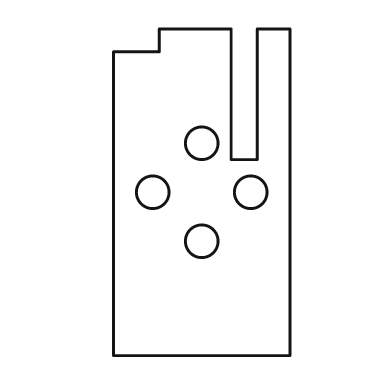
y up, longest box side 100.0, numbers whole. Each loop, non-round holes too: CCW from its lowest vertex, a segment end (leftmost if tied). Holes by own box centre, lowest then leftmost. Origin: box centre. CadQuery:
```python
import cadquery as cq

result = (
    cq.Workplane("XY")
    .moveTo(-27.0, -50.0)
    .lineTo(27.0, -50.0)
    .lineTo(27.0, 50.0)
    .lineTo(17.0, 50.0)
    .lineTo(17.0, 10.0)
    .lineTo(9.0, 10.0)
    .lineTo(9.0, 50.0)
    .lineTo(-13.0, 50.0)
    .lineTo(-13.0, 43.0)
    .lineTo(-27.0, 43.0)
    .close()
    .moveTo(0.0, -15.0)
    .circle(5.0)
    .moveTo(-15.0, 0.0)
    .circle(5.0)
    .moveTo(15.0, 0.0)
    .circle(5.0)
    .moveTo(0.0, 15.0)
    .circle(5.0)
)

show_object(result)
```